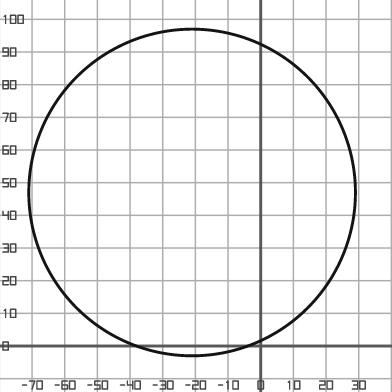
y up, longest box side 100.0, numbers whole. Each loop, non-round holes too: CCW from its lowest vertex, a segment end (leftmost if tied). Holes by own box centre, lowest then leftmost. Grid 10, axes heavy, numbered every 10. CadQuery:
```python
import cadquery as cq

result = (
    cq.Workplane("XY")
    .moveTo(-21.0, 47.0)
    .circle(50.0)
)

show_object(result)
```